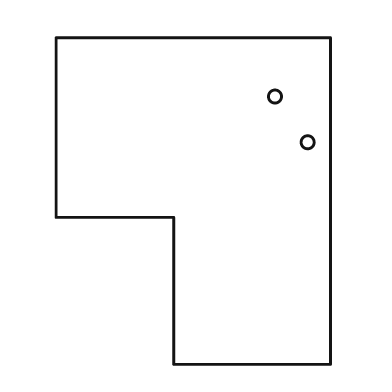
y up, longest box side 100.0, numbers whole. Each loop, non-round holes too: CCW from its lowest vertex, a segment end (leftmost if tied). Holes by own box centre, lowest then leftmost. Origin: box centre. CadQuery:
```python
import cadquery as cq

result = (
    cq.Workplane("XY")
    .moveTo(-6.0, -50.0)
    .lineTo(42.0, -50.0)
    .lineTo(42.0, 50.0)
    .lineTo(-42.0, 50.0)
    .lineTo(-42.0, -5.0)
    .lineTo(-6.0, -5.0)
    .close()
    .moveTo(35.0, 18.0)
    .circle(2.0)
    .moveTo(25.0, 32.0)
    .circle(2.0)
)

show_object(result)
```